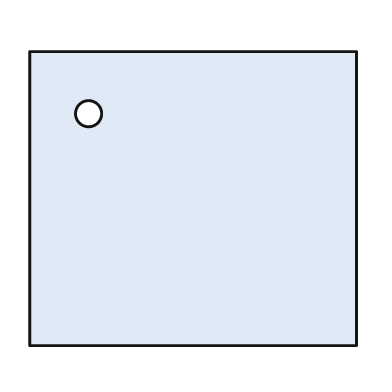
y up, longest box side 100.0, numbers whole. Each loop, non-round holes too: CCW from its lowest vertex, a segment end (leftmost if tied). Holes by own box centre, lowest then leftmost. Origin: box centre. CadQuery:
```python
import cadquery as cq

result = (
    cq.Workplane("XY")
    .moveTo(-50.0, -45.0)
    .lineTo(50.0, -45.0)
    .lineTo(50.0, 45.0)
    .lineTo(-50.0, 45.0)
    .close()
    .moveTo(-32.0, 26.0)
    .circle(4.0)
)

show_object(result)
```